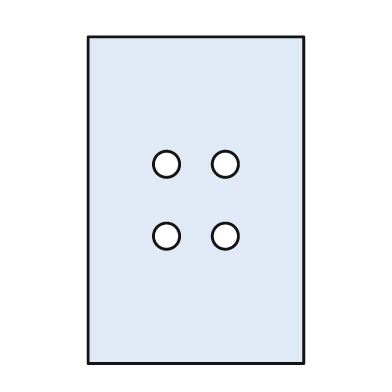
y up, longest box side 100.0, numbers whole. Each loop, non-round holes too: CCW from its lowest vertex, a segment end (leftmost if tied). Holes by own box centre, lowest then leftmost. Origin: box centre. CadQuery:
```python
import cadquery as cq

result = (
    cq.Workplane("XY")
    .moveTo(-33.0, -50.0)
    .lineTo(33.0, -50.0)
    .lineTo(33.0, 50.0)
    .lineTo(-33.0, 50.0)
    .close()
    .moveTo(-9.0, -11.0)
    .circle(4.0)
    .moveTo(9.0, -11.0)
    .circle(4.0)
    .moveTo(-9.0, 11.0)
    .circle(4.0)
    .moveTo(9.0, 11.0)
    .circle(4.0)
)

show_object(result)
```